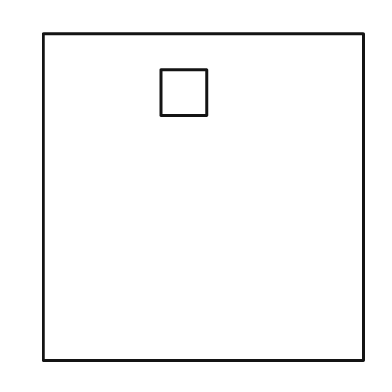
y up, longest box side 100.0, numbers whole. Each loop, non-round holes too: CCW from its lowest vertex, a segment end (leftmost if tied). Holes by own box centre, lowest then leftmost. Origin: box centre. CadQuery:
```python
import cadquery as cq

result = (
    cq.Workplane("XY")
    .moveTo(-49.0, -50.0)
    .lineTo(49.0, -50.0)
    .lineTo(49.0, 50.0)
    .lineTo(-49.0, 50.0)
    .close()
    .moveTo(-13.0, 25.0)
    .lineTo(1.0, 25.0)
    .lineTo(1.0, 39.0)
    .lineTo(-13.0, 39.0)
    .close()
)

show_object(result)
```